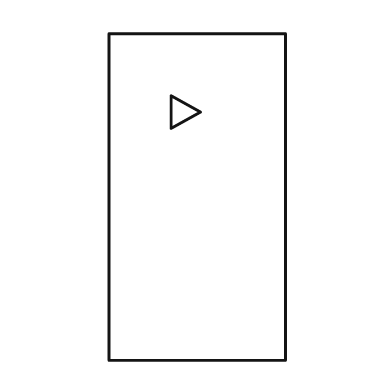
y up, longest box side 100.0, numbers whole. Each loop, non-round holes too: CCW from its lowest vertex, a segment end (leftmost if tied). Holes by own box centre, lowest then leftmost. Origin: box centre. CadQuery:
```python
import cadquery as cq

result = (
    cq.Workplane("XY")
    .moveTo(-27.0, -50.0)
    .lineTo(27.0, -50.0)
    .lineTo(27.0, 50.0)
    .lineTo(-27.0, 50.0)
    .close()
    .moveTo(-8.0, 21.0)
    .lineTo(1.0, 26.0)
    .lineTo(-8.0, 31.0)
    .close()
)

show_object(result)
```